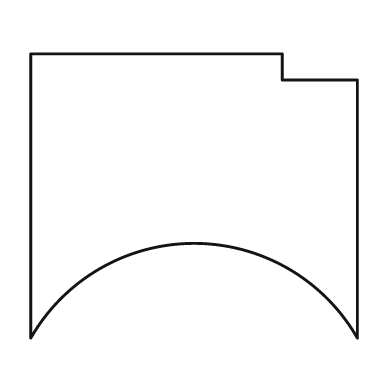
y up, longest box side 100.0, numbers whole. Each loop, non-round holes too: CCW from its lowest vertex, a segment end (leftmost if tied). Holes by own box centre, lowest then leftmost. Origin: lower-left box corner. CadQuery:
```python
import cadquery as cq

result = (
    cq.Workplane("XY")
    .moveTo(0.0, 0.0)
    .threePointArc((50.0, 29.0), (100.0, 0.0))
    .lineTo(100.0, 79.0)
    .lineTo(77.0, 79.0)
    .lineTo(77.0, 87.0)
    .lineTo(0.0, 87.0)
    .close()
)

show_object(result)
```